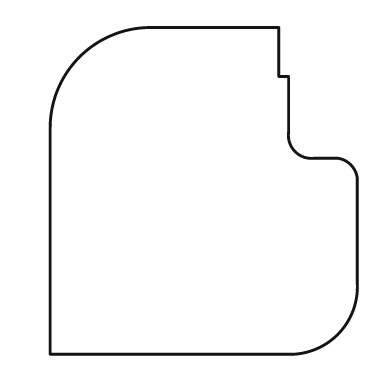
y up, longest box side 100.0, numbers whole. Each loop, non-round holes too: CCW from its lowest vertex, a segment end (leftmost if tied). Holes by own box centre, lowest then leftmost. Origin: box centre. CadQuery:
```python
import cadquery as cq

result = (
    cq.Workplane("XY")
    .moveTo(-47.0, -50.0)
    .lineTo(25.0, -50.0)
    .threePointArc((41.0, -44.0), (47.0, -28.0))
    .lineTo(47.0, 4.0)
    .threePointArc((45.0, 8.0), (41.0, 10.0))
    .lineTo(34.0, 10.0)
    .threePointArc((28.0, 12.0), (26.0, 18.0))
    .lineTo(26.0, 35.0)
    .lineTo(23.0, 35.0)
    .lineTo(23.0, 50.0)
    .lineTo(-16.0, 50.0)
    .threePointArc((-38.0, 41.0), (-47.0, 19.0))
    .close()
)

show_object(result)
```